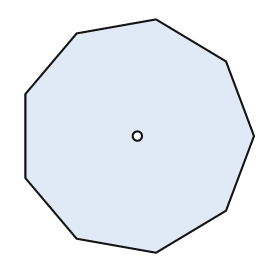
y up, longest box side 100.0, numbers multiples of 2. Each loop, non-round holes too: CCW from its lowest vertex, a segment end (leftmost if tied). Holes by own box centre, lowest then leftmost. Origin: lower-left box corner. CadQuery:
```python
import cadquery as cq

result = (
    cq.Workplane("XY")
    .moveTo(56.0, 0.0)
    .lineTo(86.0, 18.0)
    .lineTo(98.0, 50.0)
    .lineTo(86.0, 82.0)
    .lineTo(56.0, 100.0)
    .lineTo(22.0, 94.0)
    .lineTo(0.0, 68.0)
    .lineTo(0.0, 32.0)
    .lineTo(22.0, 6.0)
    .close()
    .moveTo(48.0, 50.0)
    .circle(2.0)
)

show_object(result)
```